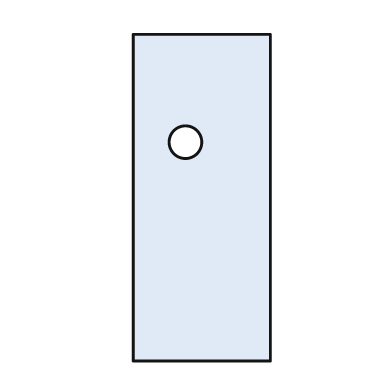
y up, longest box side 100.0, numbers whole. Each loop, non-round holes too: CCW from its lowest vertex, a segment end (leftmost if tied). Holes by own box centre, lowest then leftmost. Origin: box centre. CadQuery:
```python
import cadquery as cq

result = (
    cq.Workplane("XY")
    .moveTo(-21.0, -50.0)
    .lineTo(21.0, -50.0)
    .lineTo(21.0, 50.0)
    .lineTo(-21.0, 50.0)
    .close()
    .moveTo(-5.0, 17.0)
    .circle(5.0)
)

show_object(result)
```